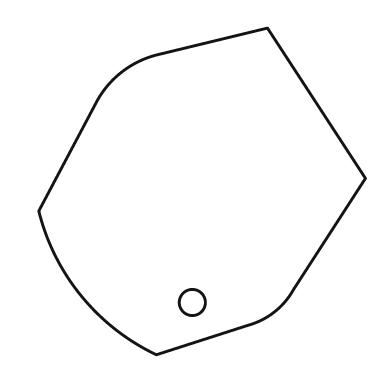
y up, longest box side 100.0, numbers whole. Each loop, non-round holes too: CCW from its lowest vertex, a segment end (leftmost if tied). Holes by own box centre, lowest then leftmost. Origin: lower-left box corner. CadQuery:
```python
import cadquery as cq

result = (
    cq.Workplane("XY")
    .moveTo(36.0, 0.0)
    .lineTo(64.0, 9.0)
    .threePointArc((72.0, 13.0), (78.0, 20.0))
    .lineTo(100.0, 54.0)
    .lineTo(70.0, 100.0)
    .lineTo(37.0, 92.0)
    .threePointArc((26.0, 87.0), (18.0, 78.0))
    .lineTo(0.0, 44.0)
    .threePointArc((13.0, 18.0), (36.0, 0.0))
    .close()
    .moveTo(47.0, 16.0)
    .circle(4.0)
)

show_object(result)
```